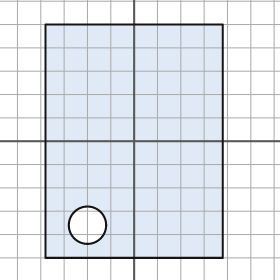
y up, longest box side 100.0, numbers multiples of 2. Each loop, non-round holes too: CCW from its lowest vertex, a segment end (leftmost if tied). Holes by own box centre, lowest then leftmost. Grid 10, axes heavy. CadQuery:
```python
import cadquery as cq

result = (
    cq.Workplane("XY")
    .moveTo(-38.0, -50.0)
    .lineTo(38.0, -50.0)
    .lineTo(38.0, 50.0)
    .lineTo(-38.0, 50.0)
    .close()
    .moveTo(-20.0, -36.0)
    .circle(8.0)
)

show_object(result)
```